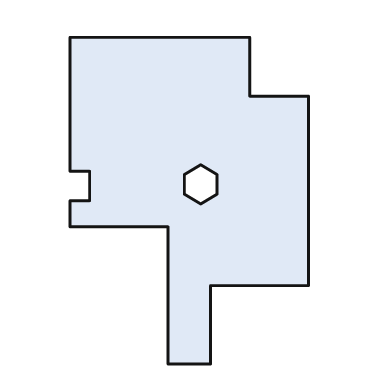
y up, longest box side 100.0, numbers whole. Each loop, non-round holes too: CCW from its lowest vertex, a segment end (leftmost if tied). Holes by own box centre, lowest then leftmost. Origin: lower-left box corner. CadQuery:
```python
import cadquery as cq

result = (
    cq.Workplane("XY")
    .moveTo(30.0, 0.0)
    .lineTo(43.0, 0.0)
    .lineTo(43.0, 24.0)
    .lineTo(73.0, 24.0)
    .lineTo(73.0, 82.0)
    .lineTo(55.0, 82.0)
    .lineTo(55.0, 100.0)
    .lineTo(0.0, 100.0)
    .lineTo(0.0, 59.0)
    .lineTo(6.0, 59.0)
    .lineTo(6.0, 50.0)
    .lineTo(0.0, 50.0)
    .lineTo(0.0, 42.0)
    .lineTo(30.0, 42.0)
    .close()
    .moveTo(40.0, 49.0)
    .lineTo(45.0, 52.0)
    .lineTo(45.0, 58.0)
    .lineTo(40.0, 61.0)
    .lineTo(35.0, 58.0)
    .lineTo(35.0, 52.0)
    .close()
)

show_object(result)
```